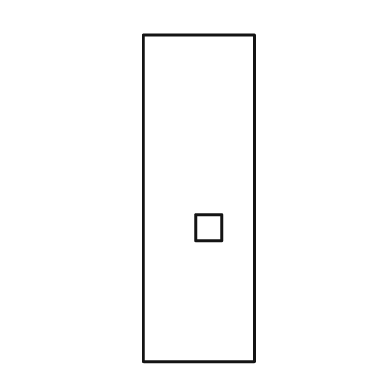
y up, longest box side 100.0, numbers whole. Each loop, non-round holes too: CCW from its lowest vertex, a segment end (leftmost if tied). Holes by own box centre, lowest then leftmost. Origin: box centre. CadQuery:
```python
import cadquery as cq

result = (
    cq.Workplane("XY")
    .moveTo(-17.0, -50.0)
    .lineTo(17.0, -50.0)
    .lineTo(17.0, 50.0)
    .lineTo(-17.0, 50.0)
    .close()
    .moveTo(-1.0, -13.0)
    .lineTo(7.0, -13.0)
    .lineTo(7.0, -5.0)
    .lineTo(-1.0, -5.0)
    .close()
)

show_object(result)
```